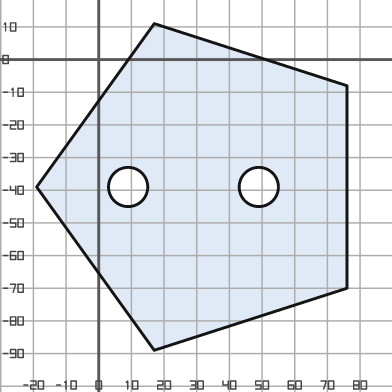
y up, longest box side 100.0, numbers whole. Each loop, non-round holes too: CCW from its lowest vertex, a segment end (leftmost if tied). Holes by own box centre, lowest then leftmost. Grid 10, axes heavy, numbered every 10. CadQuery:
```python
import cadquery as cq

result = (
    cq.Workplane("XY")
    .moveTo(17.0, -89.0)
    .lineTo(76.0, -70.0)
    .lineTo(76.0, -8.0)
    .lineTo(17.0, 11.0)
    .lineTo(-19.0, -39.0)
    .close()
    .moveTo(9.0, -39.0)
    .circle(6.0)
    .moveTo(49.0, -39.0)
    .circle(6.0)
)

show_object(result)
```